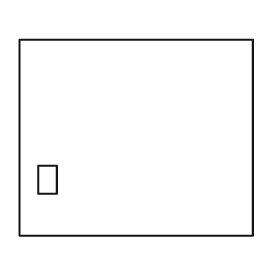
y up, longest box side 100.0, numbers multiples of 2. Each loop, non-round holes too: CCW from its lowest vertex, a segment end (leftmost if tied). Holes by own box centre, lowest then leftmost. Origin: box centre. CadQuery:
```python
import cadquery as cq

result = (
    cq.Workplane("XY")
    .moveTo(-50.0, -42.0)
    .lineTo(50.0, -42.0)
    .lineTo(50.0, 42.0)
    .lineTo(-50.0, 42.0)
    .close()
    .moveTo(-42.0, -24.0)
    .lineTo(-34.0, -24.0)
    .lineTo(-34.0, -12.0)
    .lineTo(-42.0, -12.0)
    .close()
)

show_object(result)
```